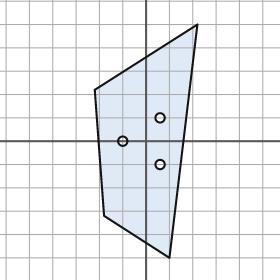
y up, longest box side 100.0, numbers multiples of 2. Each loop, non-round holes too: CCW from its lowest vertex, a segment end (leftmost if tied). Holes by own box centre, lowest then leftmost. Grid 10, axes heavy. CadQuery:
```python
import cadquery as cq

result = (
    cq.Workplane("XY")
    .moveTo(10.0, -50.0)
    .lineTo(22.0, 50.0)
    .lineTo(-22.0, 22.0)
    .lineTo(-18.0, -32.0)
    .close()
    .moveTo(6.0, -10.0)
    .circle(2.0)
    .moveTo(-10.0, 0.0)
    .circle(2.0)
    .moveTo(6.0, 10.0)
    .circle(2.0)
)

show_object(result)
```